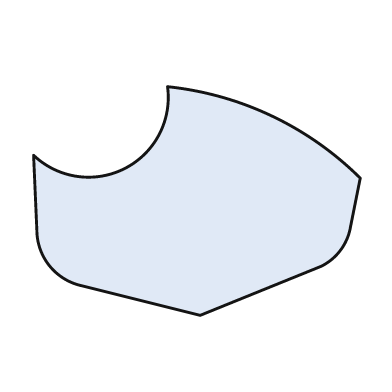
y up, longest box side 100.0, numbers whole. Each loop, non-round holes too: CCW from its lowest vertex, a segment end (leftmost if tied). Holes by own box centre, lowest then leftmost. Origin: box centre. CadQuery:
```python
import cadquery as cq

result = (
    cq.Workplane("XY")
    .moveTo(1.0, -35.0)
    .lineTo(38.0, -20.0)
    .threePointArc((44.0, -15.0), (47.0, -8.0))
    .lineTo(50.0, 7.0)
    .threePointArc((23.0, 26.0), (-9.0, 35.0))
    .threePointArc((-22.0, 10.0), (-50.0, 14.0))
    .lineTo(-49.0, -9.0)
    .threePointArc((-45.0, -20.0), (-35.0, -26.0))
    .close()
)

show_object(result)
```